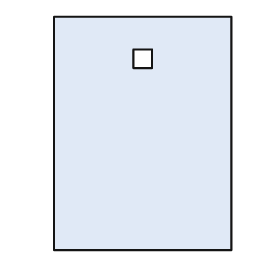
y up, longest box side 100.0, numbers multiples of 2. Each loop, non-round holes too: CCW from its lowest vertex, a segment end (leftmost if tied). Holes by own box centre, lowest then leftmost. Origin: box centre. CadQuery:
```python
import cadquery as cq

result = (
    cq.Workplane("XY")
    .moveTo(-38.0, -50.0)
    .lineTo(38.0, -50.0)
    .lineTo(38.0, 50.0)
    .lineTo(-38.0, 50.0)
    .close()
    .moveTo(-4.0, 28.0)
    .lineTo(4.0, 28.0)
    .lineTo(4.0, 36.0)
    .lineTo(-4.0, 36.0)
    .close()
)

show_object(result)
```